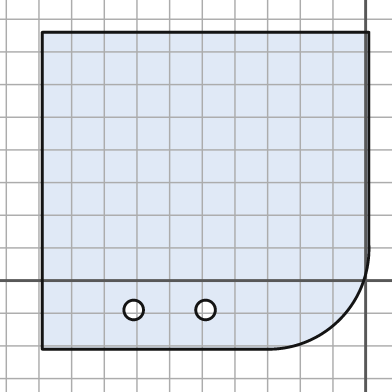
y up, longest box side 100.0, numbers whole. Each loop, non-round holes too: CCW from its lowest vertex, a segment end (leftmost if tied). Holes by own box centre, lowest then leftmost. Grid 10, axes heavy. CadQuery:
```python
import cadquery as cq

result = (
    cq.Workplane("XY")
    .moveTo(-99.0, -21.0)
    .lineTo(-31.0, -21.0)
    .threePointArc((-8.0, -12.0), (1.0, 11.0))
    .lineTo(1.0, 76.0)
    .lineTo(-99.0, 76.0)
    .close()
    .moveTo(-71.0, -9.0)
    .circle(3.0)
    .moveTo(-49.0, -9.0)
    .circle(3.0)
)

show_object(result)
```